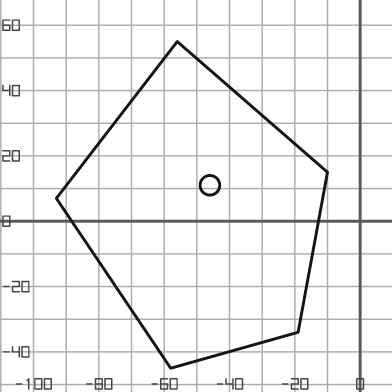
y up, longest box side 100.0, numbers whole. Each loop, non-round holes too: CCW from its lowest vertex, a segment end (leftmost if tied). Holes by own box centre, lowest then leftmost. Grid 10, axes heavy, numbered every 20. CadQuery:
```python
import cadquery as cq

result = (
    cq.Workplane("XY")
    .moveTo(-58.0, -45.0)
    .lineTo(-19.0, -34.0)
    .lineTo(-10.0, 15.0)
    .lineTo(-56.0, 55.0)
    .lineTo(-93.0, 7.0)
    .close()
    .moveTo(-46.0, 11.0)
    .circle(3.0)
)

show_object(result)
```